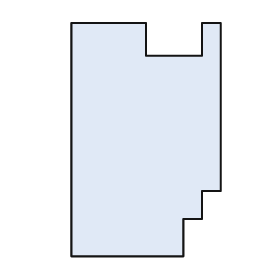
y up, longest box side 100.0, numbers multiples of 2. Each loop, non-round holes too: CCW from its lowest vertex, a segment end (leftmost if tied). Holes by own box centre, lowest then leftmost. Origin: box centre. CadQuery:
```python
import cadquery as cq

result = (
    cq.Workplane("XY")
    .moveTo(-32.0, -50.0)
    .lineTo(16.0, -50.0)
    .lineTo(16.0, -34.0)
    .lineTo(24.0, -34.0)
    .lineTo(24.0, -22.0)
    .lineTo(32.0, -22.0)
    .lineTo(32.0, 50.0)
    .lineTo(24.0, 50.0)
    .lineTo(24.0, 36.0)
    .lineTo(0.0, 36.0)
    .lineTo(0.0, 50.0)
    .lineTo(-32.0, 50.0)
    .close()
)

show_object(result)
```